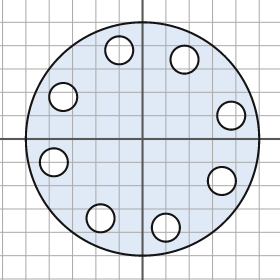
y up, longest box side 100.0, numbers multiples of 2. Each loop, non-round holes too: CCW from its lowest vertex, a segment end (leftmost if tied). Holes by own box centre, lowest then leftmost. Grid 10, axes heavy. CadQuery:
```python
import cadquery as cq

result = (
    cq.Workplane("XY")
    .moveTo(0.0, 0.0)
    .circle(50.0)
    .moveTo(10.0, -38.0)
    .circle(6.0)
    .moveTo(-18.0, -34.0)
    .circle(6.0)
    .moveTo(34.0, -18.0)
    .circle(6.0)
    .moveTo(-38.0, -10.0)
    .circle(6.0)
    .moveTo(38.0, 10.0)
    .circle(6.0)
    .moveTo(-34.0, 18.0)
    .circle(6.0)
    .moveTo(18.0, 34.0)
    .circle(6.0)
    .moveTo(-10.0, 38.0)
    .circle(6.0)
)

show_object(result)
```